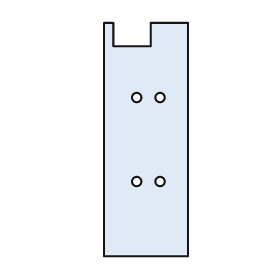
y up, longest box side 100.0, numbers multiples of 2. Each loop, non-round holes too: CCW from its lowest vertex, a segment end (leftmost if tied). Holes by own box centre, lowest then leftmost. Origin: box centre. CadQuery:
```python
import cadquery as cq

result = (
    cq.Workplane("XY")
    .moveTo(-18.0, -50.0)
    .lineTo(18.0, -50.0)
    .lineTo(18.0, 50.0)
    .lineTo(2.0, 50.0)
    .lineTo(2.0, 40.0)
    .lineTo(-14.0, 40.0)
    .lineTo(-14.0, 50.0)
    .lineTo(-18.0, 50.0)
    .close()
    .moveTo(-4.0, -18.0)
    .circle(2.0)
    .moveTo(6.0, -18.0)
    .circle(2.0)
    .moveTo(-4.0, 18.0)
    .circle(2.0)
    .moveTo(6.0, 18.0)
    .circle(2.0)
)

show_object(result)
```